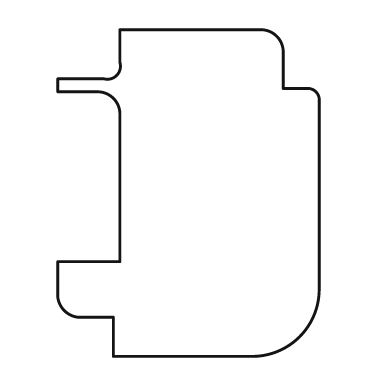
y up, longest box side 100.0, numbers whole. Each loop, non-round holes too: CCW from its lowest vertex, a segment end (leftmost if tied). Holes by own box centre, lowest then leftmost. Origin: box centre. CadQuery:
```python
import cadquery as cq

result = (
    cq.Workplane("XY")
    .moveTo(-23.0, -50.0)
    .lineTo(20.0, -50.0)
    .threePointArc((34.0, -44.0), (40.0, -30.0))
    .lineTo(40.0, 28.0)
    .threePointArc((39.0, 31.0), (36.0, 32.0))
    .lineTo(29.0, 32.0)
    .lineTo(29.0, 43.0)
    .threePointArc((27.0, 48.0), (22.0, 50.0))
    .lineTo(-21.0, 50.0)
    .lineTo(-21.0, 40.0)
    .threePointArc((-22.0, 36.0), (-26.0, 35.0))
    .lineTo(-40.0, 35.0)
    .lineTo(-40.0, 31.0)
    .lineTo(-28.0, 31.0)
    .threePointArc((-23.0, 29.0), (-21.0, 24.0))
    .lineTo(-21.0, -21.0)
    .lineTo(-40.0, -21.0)
    .lineTo(-40.0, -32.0)
    .threePointArc((-38.0, -36.0), (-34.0, -38.0))
    .lineTo(-23.0, -38.0)
    .close()
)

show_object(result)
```